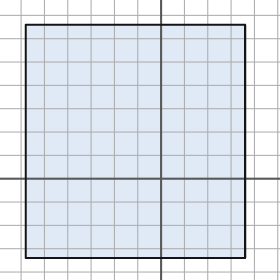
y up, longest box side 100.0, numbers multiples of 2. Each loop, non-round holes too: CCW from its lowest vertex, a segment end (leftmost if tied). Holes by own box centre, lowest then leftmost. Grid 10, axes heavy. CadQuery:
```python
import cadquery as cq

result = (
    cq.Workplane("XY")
    .moveTo(-58.0, -34.0)
    .lineTo(36.0, -34.0)
    .lineTo(36.0, 66.0)
    .lineTo(-58.0, 66.0)
    .close()
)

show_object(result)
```